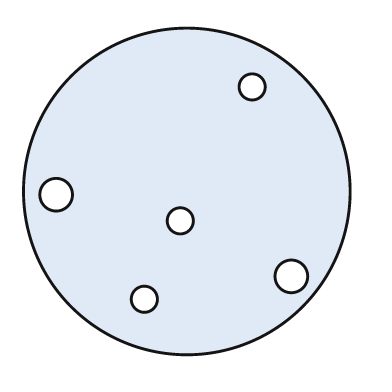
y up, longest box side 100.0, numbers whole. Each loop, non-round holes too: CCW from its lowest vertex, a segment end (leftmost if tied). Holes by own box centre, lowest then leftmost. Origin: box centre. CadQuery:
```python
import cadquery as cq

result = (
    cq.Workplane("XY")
    .moveTo(0.0, 0.0)
    .circle(50.0)
    .moveTo(-13.0, -33.0)
    .circle(4.0)
    .moveTo(32.0, -26.0)
    .circle(5.0)
    .moveTo(-2.0, -9.0)
    .circle(4.0)
    .moveTo(-40.0, -1.0)
    .circle(5.0)
    .moveTo(20.0, 32.0)
    .circle(4.0)
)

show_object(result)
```